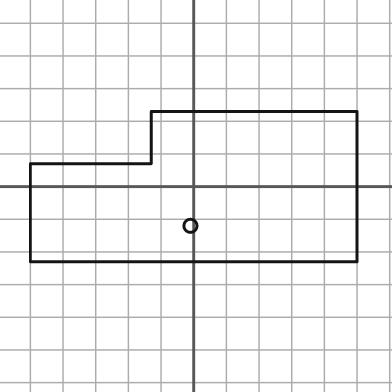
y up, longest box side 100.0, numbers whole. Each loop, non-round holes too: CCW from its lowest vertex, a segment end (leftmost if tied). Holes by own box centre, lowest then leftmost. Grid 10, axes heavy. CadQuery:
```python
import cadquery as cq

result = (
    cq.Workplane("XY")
    .moveTo(-50.0, -23.0)
    .lineTo(50.0, -23.0)
    .lineTo(50.0, 23.0)
    .lineTo(-13.0, 23.0)
    .lineTo(-13.0, 7.0)
    .lineTo(-50.0, 7.0)
    .close()
    .moveTo(-1.0, -12.0)
    .circle(2.0)
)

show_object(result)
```